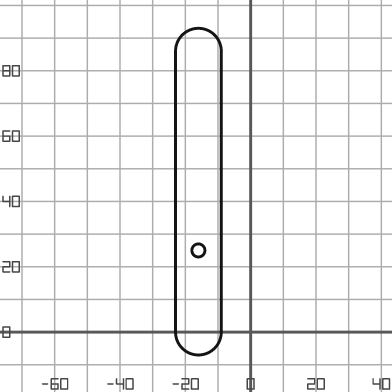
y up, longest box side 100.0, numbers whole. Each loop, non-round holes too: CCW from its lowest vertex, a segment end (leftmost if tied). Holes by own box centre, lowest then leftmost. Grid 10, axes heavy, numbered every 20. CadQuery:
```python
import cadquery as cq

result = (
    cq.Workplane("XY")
    .moveTo(-23.0, 0.0)
    .threePointArc((-16.0, -7.0), (-9.0, 0.0))
    .lineTo(-9.0, 86.0)
    .threePointArc((-16.0, 93.0), (-23.0, 86.0))
    .close()
    .moveTo(-16.0, 25.0)
    .circle(2.0)
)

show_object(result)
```